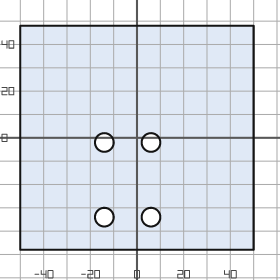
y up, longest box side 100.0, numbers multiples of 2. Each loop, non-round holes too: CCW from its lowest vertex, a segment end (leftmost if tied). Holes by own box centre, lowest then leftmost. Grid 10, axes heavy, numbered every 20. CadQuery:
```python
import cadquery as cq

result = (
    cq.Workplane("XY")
    .moveTo(-50.0, -48.0)
    .lineTo(50.0, -48.0)
    .lineTo(50.0, 48.0)
    .lineTo(-50.0, 48.0)
    .close()
    .moveTo(-14.0, -34.0)
    .circle(4.0)
    .moveTo(6.0, -34.0)
    .circle(4.0)
    .moveTo(-14.0, -2.0)
    .circle(4.0)
    .moveTo(6.0, -2.0)
    .circle(4.0)
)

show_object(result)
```